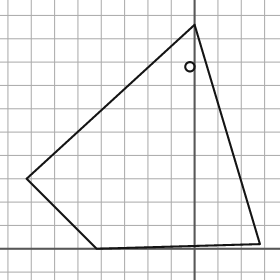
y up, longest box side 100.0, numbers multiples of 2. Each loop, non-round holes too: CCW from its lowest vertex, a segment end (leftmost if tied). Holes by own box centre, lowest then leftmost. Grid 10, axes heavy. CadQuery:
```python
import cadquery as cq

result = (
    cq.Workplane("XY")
    .moveTo(-42.0, 0.0)
    .lineTo(28.0, 2.0)
    .lineTo(0.0, 96.0)
    .lineTo(-72.0, 30.0)
    .close()
    .moveTo(-2.0, 78.0)
    .circle(2.0)
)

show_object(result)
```